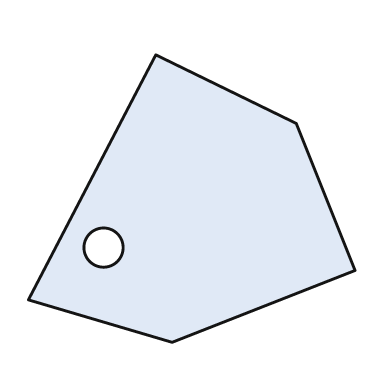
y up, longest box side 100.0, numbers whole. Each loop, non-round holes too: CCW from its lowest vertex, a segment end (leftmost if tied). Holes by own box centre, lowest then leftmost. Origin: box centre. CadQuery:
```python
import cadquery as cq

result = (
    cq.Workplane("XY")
    .moveTo(-6.0, -44.0)
    .lineTo(50.0, -22.0)
    .lineTo(32.0, 23.0)
    .lineTo(-11.0, 44.0)
    .lineTo(-50.0, -31.0)
    .close()
    .moveTo(-27.0, -15.0)
    .circle(6.0)
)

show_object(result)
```